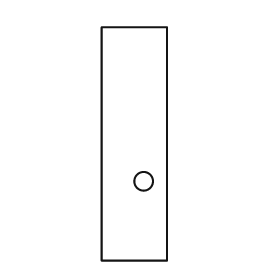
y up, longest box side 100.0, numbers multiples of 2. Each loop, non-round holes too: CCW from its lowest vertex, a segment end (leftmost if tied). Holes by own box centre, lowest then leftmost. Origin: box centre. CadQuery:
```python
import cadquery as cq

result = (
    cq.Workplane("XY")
    .moveTo(-14.0, -50.0)
    .lineTo(14.0, -50.0)
    .lineTo(14.0, 50.0)
    .lineTo(-14.0, 50.0)
    .close()
    .moveTo(4.0, -16.0)
    .circle(4.0)
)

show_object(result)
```